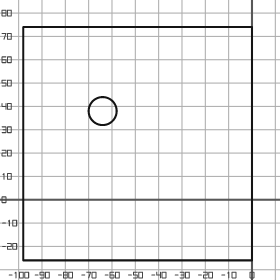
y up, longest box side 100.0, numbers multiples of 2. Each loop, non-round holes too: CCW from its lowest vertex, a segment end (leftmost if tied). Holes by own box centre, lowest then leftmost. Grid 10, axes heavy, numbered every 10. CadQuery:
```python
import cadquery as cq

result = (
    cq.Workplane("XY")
    .moveTo(-98.0, -26.0)
    .lineTo(0.0, -26.0)
    .lineTo(0.0, 74.0)
    .lineTo(-98.0, 74.0)
    .close()
    .moveTo(-64.0, 38.0)
    .circle(6.0)
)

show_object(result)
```